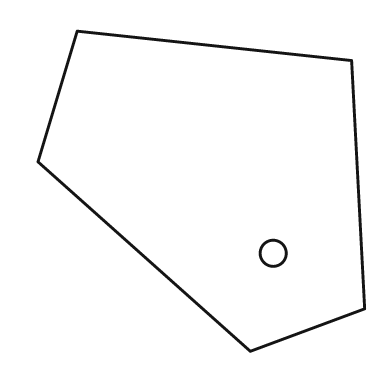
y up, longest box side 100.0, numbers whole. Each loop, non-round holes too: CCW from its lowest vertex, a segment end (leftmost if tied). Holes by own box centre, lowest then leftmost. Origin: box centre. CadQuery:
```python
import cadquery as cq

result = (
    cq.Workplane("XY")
    .moveTo(15.0, -49.0)
    .lineTo(50.0, -36.0)
    .lineTo(46.0, 40.0)
    .lineTo(-38.0, 49.0)
    .lineTo(-50.0, 9.0)
    .close()
    .moveTo(22.0, -19.0)
    .circle(4.0)
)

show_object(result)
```